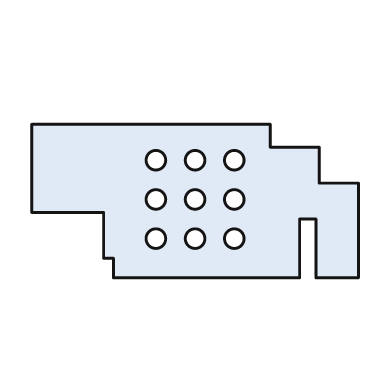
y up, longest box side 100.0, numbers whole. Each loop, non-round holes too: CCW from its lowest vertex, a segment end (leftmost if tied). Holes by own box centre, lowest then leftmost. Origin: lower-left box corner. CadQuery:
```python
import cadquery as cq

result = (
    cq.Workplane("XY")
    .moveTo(25.0, 0.0)
    .lineTo(82.0, 0.0)
    .lineTo(82.0, 18.0)
    .lineTo(87.0, 18.0)
    .lineTo(87.0, 0.0)
    .lineTo(100.0, 0.0)
    .lineTo(100.0, 29.0)
    .lineTo(88.0, 29.0)
    .lineTo(88.0, 40.0)
    .lineTo(73.0, 40.0)
    .lineTo(73.0, 47.0)
    .lineTo(0.0, 47.0)
    .lineTo(0.0, 20.0)
    .lineTo(22.0, 20.0)
    .lineTo(22.0, 6.0)
    .lineTo(25.0, 6.0)
    .close()
    .moveTo(38.0, 12.0)
    .circle(3.0)
    .moveTo(50.0, 12.0)
    .circle(3.0)
    .moveTo(62.0, 12.0)
    .circle(3.0)
    .moveTo(38.0, 24.0)
    .circle(3.0)
    .moveTo(50.0, 24.0)
    .circle(3.0)
    .moveTo(62.0, 24.0)
    .circle(3.0)
    .moveTo(38.0, 36.0)
    .circle(3.0)
    .moveTo(50.0, 36.0)
    .circle(3.0)
    .moveTo(62.0, 36.0)
    .circle(3.0)
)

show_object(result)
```